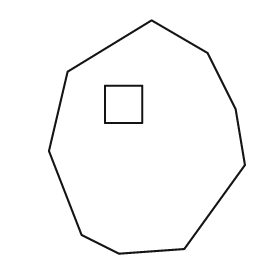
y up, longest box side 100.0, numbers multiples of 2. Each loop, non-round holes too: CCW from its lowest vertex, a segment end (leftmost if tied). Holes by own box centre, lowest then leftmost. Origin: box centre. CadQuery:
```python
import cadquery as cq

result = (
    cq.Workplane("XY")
    .moveTo(-12.0, -50.0)
    .lineTo(16.0, -48.0)
    .lineTo(42.0, -12.0)
    .lineTo(38.0, 12.0)
    .lineTo(26.0, 36.0)
    .lineTo(2.0, 50.0)
    .lineTo(-34.0, 28.0)
    .lineTo(-42.0, -6.0)
    .lineTo(-28.0, -42.0)
    .close()
    .moveTo(-18.0, 6.0)
    .lineTo(-2.0, 6.0)
    .lineTo(-2.0, 22.0)
    .lineTo(-18.0, 22.0)
    .close()
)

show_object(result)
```